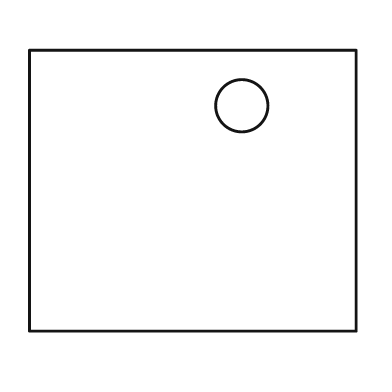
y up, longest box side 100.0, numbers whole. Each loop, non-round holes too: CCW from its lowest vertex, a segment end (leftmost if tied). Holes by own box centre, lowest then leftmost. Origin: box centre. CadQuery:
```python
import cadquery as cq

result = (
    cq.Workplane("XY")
    .moveTo(-50.0, -43.0)
    .lineTo(50.0, -43.0)
    .lineTo(50.0, 43.0)
    .lineTo(-50.0, 43.0)
    .close()
    .moveTo(15.0, 26.0)
    .circle(8.0)
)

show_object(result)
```